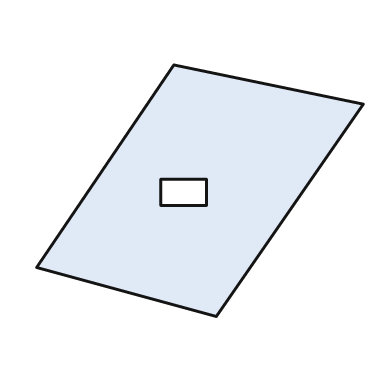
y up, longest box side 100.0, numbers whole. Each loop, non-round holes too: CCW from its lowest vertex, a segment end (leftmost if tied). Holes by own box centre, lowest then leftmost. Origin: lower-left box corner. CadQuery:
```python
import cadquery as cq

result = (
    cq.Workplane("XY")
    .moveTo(55.0, 0.0)
    .lineTo(100.0, 65.0)
    .lineTo(42.0, 77.0)
    .lineTo(0.0, 15.0)
    .close()
    .moveTo(38.0, 34.0)
    .lineTo(52.0, 34.0)
    .lineTo(52.0, 42.0)
    .lineTo(38.0, 42.0)
    .close()
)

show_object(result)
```